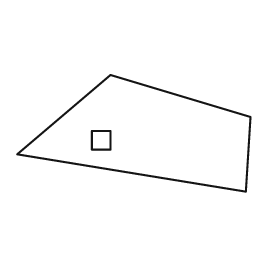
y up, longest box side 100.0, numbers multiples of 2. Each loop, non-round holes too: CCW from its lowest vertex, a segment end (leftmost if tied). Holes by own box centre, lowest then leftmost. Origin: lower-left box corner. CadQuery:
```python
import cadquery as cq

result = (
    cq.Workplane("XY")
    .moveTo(98.0, 0.0)
    .lineTo(100.0, 32.0)
    .lineTo(40.0, 50.0)
    .lineTo(0.0, 16.0)
    .close()
    .moveTo(32.0, 18.0)
    .lineTo(40.0, 18.0)
    .lineTo(40.0, 26.0)
    .lineTo(32.0, 26.0)
    .close()
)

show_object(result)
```